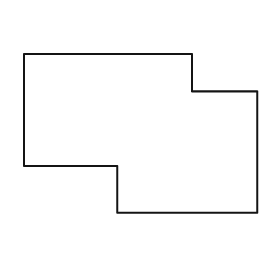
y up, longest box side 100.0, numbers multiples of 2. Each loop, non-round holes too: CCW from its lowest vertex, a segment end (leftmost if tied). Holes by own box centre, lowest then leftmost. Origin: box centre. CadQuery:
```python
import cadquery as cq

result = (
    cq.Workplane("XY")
    .moveTo(-10.0, -34.0)
    .lineTo(50.0, -34.0)
    .lineTo(50.0, 18.0)
    .lineTo(22.0, 18.0)
    .lineTo(22.0, 34.0)
    .lineTo(-50.0, 34.0)
    .lineTo(-50.0, -14.0)
    .lineTo(-10.0, -14.0)
    .close()
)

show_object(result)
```